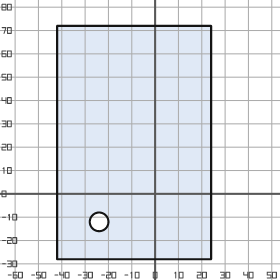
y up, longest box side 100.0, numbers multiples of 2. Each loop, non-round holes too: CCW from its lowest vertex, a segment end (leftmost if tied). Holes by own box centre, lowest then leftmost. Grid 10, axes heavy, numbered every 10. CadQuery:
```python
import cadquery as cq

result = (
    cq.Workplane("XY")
    .moveTo(-42.0, -28.0)
    .lineTo(24.0, -28.0)
    .lineTo(24.0, 72.0)
    .lineTo(-42.0, 72.0)
    .close()
    .moveTo(-24.0, -12.0)
    .circle(4.0)
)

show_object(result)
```